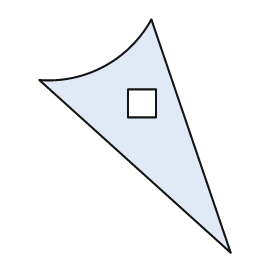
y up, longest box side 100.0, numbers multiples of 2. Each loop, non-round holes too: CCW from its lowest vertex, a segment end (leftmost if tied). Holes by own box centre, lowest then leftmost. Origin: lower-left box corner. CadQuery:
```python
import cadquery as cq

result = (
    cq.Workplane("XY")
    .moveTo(82.0, 0.0)
    .lineTo(48.0, 100.0)
    .threePointArc((28.0, 80.0), (0.0, 74.0))
    .close()
    .moveTo(38.0, 58.0)
    .lineTo(50.0, 58.0)
    .lineTo(50.0, 70.0)
    .lineTo(38.0, 70.0)
    .close()
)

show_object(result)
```